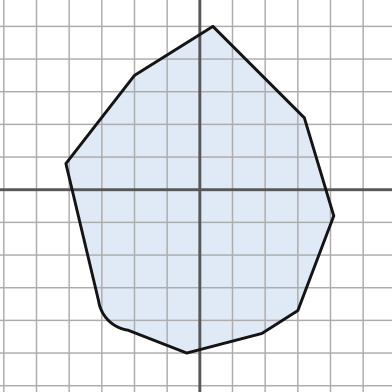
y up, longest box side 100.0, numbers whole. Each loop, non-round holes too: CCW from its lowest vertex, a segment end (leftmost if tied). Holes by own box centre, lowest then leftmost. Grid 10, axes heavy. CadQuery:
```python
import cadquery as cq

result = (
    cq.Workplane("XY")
    .moveTo(-4.0, -50.0)
    .lineTo(19.0, -44.0)
    .lineTo(30.0, -37.0)
    .lineTo(41.0, -8.0)
    .lineTo(32.0, 22.0)
    .lineTo(4.0, 50.0)
    .lineTo(-20.0, 35.0)
    .lineTo(-41.0, 8.0)
    .lineTo(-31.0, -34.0)
    .threePointArc((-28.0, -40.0), (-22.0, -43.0))
    .close()
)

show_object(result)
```